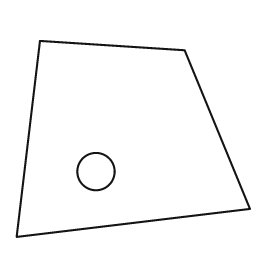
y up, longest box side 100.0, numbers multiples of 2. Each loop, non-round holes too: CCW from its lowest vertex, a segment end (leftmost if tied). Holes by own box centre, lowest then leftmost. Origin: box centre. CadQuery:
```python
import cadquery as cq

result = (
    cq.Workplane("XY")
    .moveTo(-50.0, -42.0)
    .lineTo(50.0, -30.0)
    .lineTo(22.0, 38.0)
    .lineTo(-40.0, 42.0)
    .close()
    .moveTo(-16.0, -14.0)
    .circle(8.0)
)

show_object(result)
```